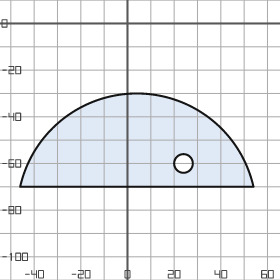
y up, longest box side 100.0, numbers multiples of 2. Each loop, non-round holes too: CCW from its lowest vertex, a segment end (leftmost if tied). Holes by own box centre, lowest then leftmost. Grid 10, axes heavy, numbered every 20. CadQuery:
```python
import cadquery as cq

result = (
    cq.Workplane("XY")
    .moveTo(-46.0, -70.0)
    .lineTo(54.0, -70.0)
    .threePointArc((4.0, -30.0), (-46.0, -70.0))
    .close()
    .moveTo(24.0, -60.0)
    .circle(4.0)
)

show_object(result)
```